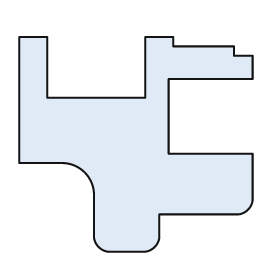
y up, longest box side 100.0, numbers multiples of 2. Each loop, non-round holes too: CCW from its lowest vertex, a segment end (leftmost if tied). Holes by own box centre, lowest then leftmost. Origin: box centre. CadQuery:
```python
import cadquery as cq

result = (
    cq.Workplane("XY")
    .moveTo(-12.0, -46.0)
    .lineTo(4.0, -46.0)
    .threePointArc((8.0, -44.0), (10.0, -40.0))
    .lineTo(10.0, -30.0)
    .lineTo(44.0, -30.0)
    .threePointArc((48.0, -28.0), (50.0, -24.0))
    .lineTo(50.0, -4.0)
    .lineTo(14.0, -4.0)
    .lineTo(14.0, 28.0)
    .lineTo(50.0, 28.0)
    .lineTo(50.0, 38.0)
    .lineTo(42.0, 38.0)
    .lineTo(42.0, 42.0)
    .lineTo(16.0, 42.0)
    .lineTo(16.0, 46.0)
    .lineTo(4.0, 46.0)
    .lineTo(4.0, 20.0)
    .lineTo(-38.0, 20.0)
    .lineTo(-38.0, 46.0)
    .lineTo(-50.0, 46.0)
    .lineTo(-50.0, -8.0)
    .lineTo(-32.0, -8.0)
    .threePointArc((-22.0, -12.0), (-18.0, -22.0))
    .lineTo(-18.0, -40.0)
    .threePointArc((-16.0, -44.0), (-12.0, -46.0))
    .close()
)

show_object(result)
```